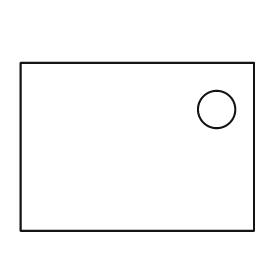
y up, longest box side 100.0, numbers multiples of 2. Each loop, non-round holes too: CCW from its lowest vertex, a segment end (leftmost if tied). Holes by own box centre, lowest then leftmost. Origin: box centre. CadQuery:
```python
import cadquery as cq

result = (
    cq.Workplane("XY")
    .moveTo(-50.0, -36.0)
    .lineTo(50.0, -36.0)
    .lineTo(50.0, 36.0)
    .lineTo(-50.0, 36.0)
    .close()
    .moveTo(34.0, 16.0)
    .circle(8.0)
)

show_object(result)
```